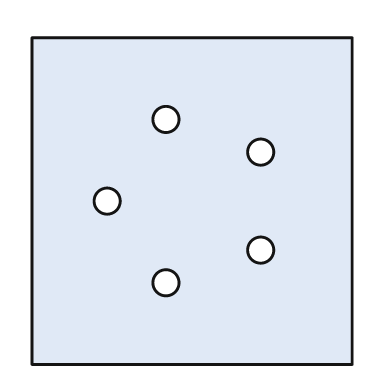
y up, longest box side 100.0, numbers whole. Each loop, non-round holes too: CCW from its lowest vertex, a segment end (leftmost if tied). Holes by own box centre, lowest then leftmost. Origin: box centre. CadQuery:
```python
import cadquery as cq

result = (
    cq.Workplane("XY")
    .moveTo(-49.0, -50.0)
    .lineTo(49.0, -50.0)
    .lineTo(49.0, 50.0)
    .lineTo(-49.0, 50.0)
    .close()
    .moveTo(-8.0, -25.0)
    .circle(4.0)
    .moveTo(21.0, -15.0)
    .circle(4.0)
    .moveTo(-26.0, 0.0)
    .circle(4.0)
    .moveTo(21.0, 15.0)
    .circle(4.0)
    .moveTo(-8.0, 25.0)
    .circle(4.0)
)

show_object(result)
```